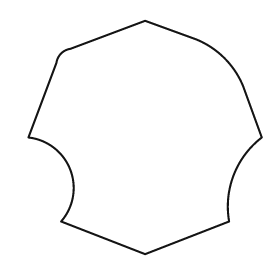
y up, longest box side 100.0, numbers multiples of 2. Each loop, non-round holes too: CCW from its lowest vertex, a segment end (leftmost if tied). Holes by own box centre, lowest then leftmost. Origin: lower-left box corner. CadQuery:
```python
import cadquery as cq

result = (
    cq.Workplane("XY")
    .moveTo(50.0, 0.0)
    .lineTo(86.0, 14.0)
    .threePointArc((88.0, 34.0), (100.0, 50.0))
    .lineTo(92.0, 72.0)
    .threePointArc((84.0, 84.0), (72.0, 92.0))
    .lineTo(50.0, 100.0)
    .lineTo(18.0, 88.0)
    .threePointArc((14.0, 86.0), (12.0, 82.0))
    .lineTo(0.0, 50.0)
    .threePointArc((18.0, 36.0), (14.0, 14.0))
    .close()
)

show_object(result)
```